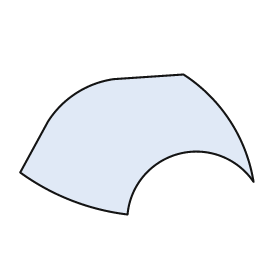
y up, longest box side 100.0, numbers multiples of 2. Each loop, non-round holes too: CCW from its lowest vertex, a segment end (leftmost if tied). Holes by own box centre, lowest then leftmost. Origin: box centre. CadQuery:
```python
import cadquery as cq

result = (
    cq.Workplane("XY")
    .moveTo(-4.0, -30.0)
    .threePointArc((18.0, -4.0), (50.0, -16.0))
    .threePointArc((40.0, 10.0), (20.0, 30.0))
    .lineTo(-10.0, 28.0)
    .threePointArc((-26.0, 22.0), (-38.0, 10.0))
    .lineTo(-50.0, -12.0)
    .threePointArc((-28.0, -24.0), (-4.0, -30.0))
    .close()
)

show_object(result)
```